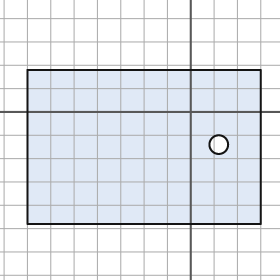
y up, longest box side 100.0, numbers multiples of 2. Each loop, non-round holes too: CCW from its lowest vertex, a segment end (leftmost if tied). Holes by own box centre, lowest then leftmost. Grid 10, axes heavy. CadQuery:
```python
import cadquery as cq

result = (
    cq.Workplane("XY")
    .moveTo(-70.0, -48.0)
    .lineTo(30.0, -48.0)
    .lineTo(30.0, 18.0)
    .lineTo(-70.0, 18.0)
    .close()
    .moveTo(12.0, -14.0)
    .circle(4.0)
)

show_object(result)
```